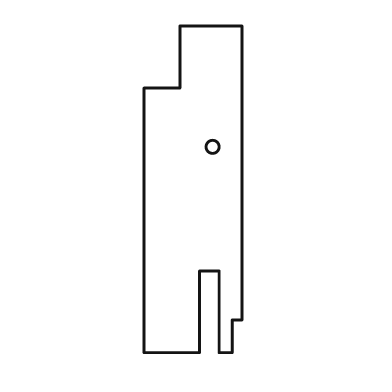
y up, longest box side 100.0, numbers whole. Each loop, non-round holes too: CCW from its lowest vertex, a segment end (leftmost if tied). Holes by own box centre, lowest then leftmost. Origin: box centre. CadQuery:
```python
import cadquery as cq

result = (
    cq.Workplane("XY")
    .moveTo(-15.0, -50.0)
    .lineTo(2.0, -50.0)
    .lineTo(2.0, -25.0)
    .lineTo(8.0, -25.0)
    .lineTo(8.0, -50.0)
    .lineTo(12.0, -50.0)
    .lineTo(12.0, -40.0)
    .lineTo(15.0, -40.0)
    .lineTo(15.0, 50.0)
    .lineTo(-4.0, 50.0)
    .lineTo(-4.0, 31.0)
    .lineTo(-15.0, 31.0)
    .close()
    .moveTo(6.0, 13.0)
    .circle(2.0)
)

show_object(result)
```